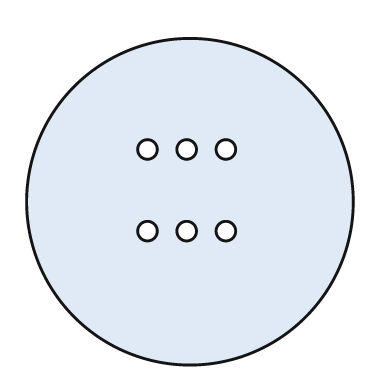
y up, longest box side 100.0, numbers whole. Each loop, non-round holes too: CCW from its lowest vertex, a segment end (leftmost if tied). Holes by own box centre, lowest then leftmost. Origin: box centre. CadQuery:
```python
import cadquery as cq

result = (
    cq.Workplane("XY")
    .moveTo(0.0, 0.0)
    .circle(50.0)
    .moveTo(-13.0, -9.0)
    .circle(3.0)
    .moveTo(-1.0, -9.0)
    .circle(3.0)
    .moveTo(11.0, -9.0)
    .circle(3.0)
    .moveTo(-13.0, 16.0)
    .circle(3.0)
    .moveTo(-1.0, 16.0)
    .circle(3.0)
    .moveTo(11.0, 16.0)
    .circle(3.0)
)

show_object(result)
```